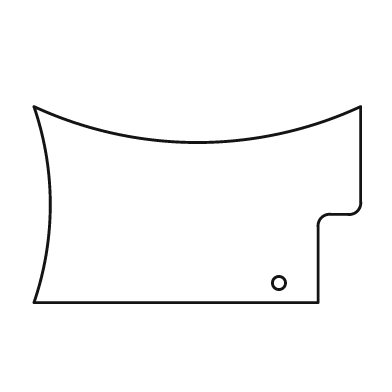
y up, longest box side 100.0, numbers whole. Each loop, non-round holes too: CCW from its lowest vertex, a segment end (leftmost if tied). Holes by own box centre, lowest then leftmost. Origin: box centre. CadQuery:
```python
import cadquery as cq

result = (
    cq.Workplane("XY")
    .moveTo(-50.0, -30.0)
    .lineTo(37.0, -30.0)
    .lineTo(37.0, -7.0)
    .threePointArc((38.0, -4.0), (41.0, -3.0))
    .lineTo(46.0, -3.0)
    .threePointArc((49.0, -2.0), (50.0, 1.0))
    .lineTo(50.0, 30.0)
    .threePointArc((0.0, 19.0), (-50.0, 30.0))
    .threePointArc((-45.0, 0.0), (-50.0, -30.0))
    .close()
    .moveTo(25.0, -24.0)
    .circle(2.0)
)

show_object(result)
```